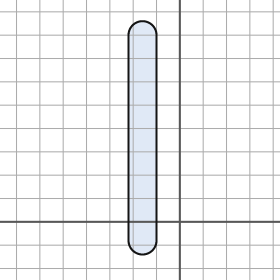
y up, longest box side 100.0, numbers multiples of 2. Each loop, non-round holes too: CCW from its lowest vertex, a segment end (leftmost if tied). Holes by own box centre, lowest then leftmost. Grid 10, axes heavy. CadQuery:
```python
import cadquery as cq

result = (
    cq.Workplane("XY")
    .moveTo(-22.0, -8.0)
    .threePointArc((-16.0, -14.0), (-10.0, -8.0))
    .lineTo(-10.0, 80.0)
    .threePointArc((-16.0, 86.0), (-22.0, 80.0))
    .close()
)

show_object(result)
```